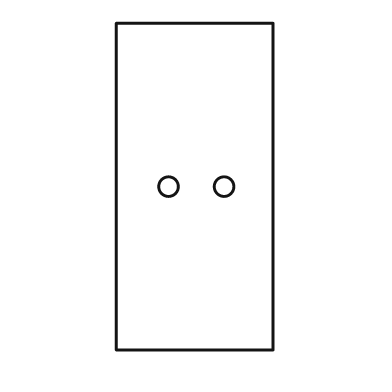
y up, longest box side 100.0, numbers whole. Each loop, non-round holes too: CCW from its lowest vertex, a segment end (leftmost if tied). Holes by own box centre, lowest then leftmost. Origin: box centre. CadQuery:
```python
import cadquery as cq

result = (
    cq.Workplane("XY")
    .moveTo(-24.0, -50.0)
    .lineTo(24.0, -50.0)
    .lineTo(24.0, 50.0)
    .lineTo(-24.0, 50.0)
    .close()
    .moveTo(-8.0, 0.0)
    .circle(3.0)
    .moveTo(9.0, 0.0)
    .circle(3.0)
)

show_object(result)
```